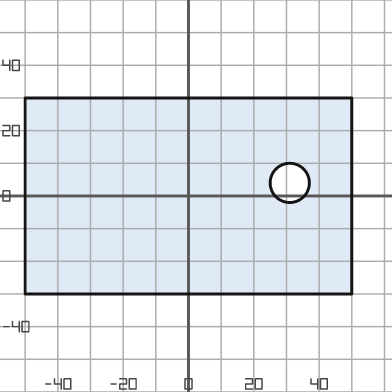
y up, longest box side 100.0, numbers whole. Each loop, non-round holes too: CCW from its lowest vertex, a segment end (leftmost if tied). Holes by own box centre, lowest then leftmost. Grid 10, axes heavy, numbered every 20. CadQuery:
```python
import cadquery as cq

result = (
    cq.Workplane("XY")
    .moveTo(-50.0, -30.0)
    .lineTo(50.0, -30.0)
    .lineTo(50.0, 30.0)
    .lineTo(-50.0, 30.0)
    .close()
    .moveTo(31.0, 4.0)
    .circle(6.0)
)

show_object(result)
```